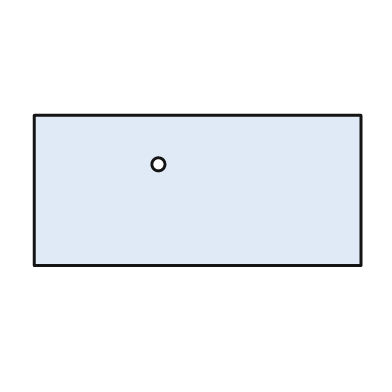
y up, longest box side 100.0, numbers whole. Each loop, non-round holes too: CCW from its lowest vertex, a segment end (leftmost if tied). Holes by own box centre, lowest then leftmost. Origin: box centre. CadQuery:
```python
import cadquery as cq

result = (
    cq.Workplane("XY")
    .moveTo(-50.0, -23.0)
    .lineTo(50.0, -23.0)
    .lineTo(50.0, 23.0)
    .lineTo(-50.0, 23.0)
    .close()
    .moveTo(-12.0, 8.0)
    .circle(2.0)
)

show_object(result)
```